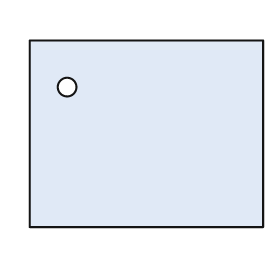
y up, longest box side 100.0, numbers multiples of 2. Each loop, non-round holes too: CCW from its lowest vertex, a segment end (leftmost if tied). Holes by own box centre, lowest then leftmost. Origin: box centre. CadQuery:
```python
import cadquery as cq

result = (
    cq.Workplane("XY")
    .moveTo(-50.0, -40.0)
    .lineTo(50.0, -40.0)
    .lineTo(50.0, 40.0)
    .lineTo(-50.0, 40.0)
    .close()
    .moveTo(-34.0, 20.0)
    .circle(4.0)
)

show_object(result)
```